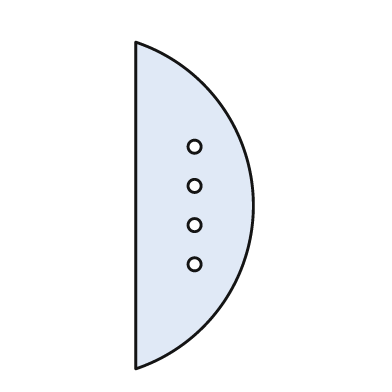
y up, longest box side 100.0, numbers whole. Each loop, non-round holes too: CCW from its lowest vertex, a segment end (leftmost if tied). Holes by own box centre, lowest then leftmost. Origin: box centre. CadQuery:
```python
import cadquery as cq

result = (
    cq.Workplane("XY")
    .moveTo(-18.0, -50.0)
    .threePointArc((18.0, 0.0), (-18.0, 50.0))
    .close()
    .moveTo(0.0, -18.0)
    .circle(2.0)
    .moveTo(0.0, -6.0)
    .circle(2.0)
    .moveTo(0.0, 6.0)
    .circle(2.0)
    .moveTo(0.0, 18.0)
    .circle(2.0)
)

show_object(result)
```